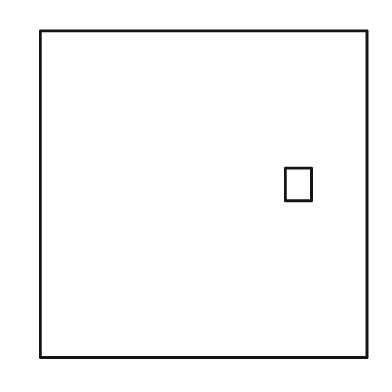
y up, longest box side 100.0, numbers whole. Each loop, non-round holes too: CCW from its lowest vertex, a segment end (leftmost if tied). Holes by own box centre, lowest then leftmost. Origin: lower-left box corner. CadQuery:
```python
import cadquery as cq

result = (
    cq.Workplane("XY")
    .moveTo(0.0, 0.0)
    .lineTo(100.0, 0.0)
    .lineTo(100.0, 100.0)
    .lineTo(0.0, 100.0)
    .close()
    .moveTo(75.0, 48.0)
    .lineTo(83.0, 48.0)
    .lineTo(83.0, 58.0)
    .lineTo(75.0, 58.0)
    .close()
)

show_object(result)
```